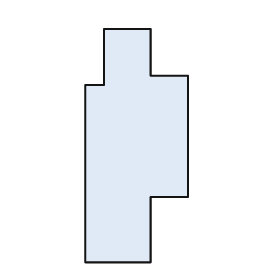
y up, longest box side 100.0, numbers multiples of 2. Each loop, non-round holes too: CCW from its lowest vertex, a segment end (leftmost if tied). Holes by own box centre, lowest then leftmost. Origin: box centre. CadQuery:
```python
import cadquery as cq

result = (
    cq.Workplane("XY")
    .moveTo(-22.0, -50.0)
    .lineTo(6.0, -50.0)
    .lineTo(6.0, -22.0)
    .lineTo(22.0, -22.0)
    .lineTo(22.0, 30.0)
    .lineTo(6.0, 30.0)
    .lineTo(6.0, 50.0)
    .lineTo(-14.0, 50.0)
    .lineTo(-14.0, 26.0)
    .lineTo(-22.0, 26.0)
    .close()
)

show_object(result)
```